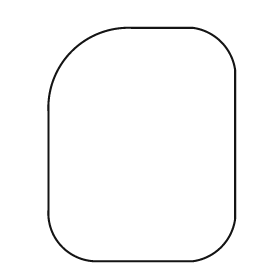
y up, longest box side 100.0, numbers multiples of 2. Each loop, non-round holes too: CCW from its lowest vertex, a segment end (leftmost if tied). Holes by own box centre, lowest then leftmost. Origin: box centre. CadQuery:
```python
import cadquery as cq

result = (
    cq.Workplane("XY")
    .moveTo(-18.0, -50.0)
    .lineTo(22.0, -50.0)
    .threePointArc((34.0, -44.0), (40.0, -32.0))
    .lineTo(40.0, 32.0)
    .threePointArc((34.0, 44.0), (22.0, 50.0))
    .lineTo(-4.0, 50.0)
    .threePointArc((-30.0, 40.0), (-40.0, 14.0))
    .lineTo(-40.0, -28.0)
    .threePointArc((-34.0, -44.0), (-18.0, -50.0))
    .close()
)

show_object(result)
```